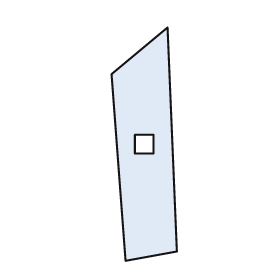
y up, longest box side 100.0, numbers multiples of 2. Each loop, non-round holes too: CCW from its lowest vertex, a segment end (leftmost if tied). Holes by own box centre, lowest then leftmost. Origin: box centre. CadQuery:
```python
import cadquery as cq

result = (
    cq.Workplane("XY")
    .moveTo(-8.0, -50.0)
    .lineTo(14.0, -46.0)
    .lineTo(10.0, 50.0)
    .lineTo(-14.0, 30.0)
    .close()
    .moveTo(-4.0, -4.0)
    .lineTo(4.0, -4.0)
    .lineTo(4.0, 4.0)
    .lineTo(-4.0, 4.0)
    .close()
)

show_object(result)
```